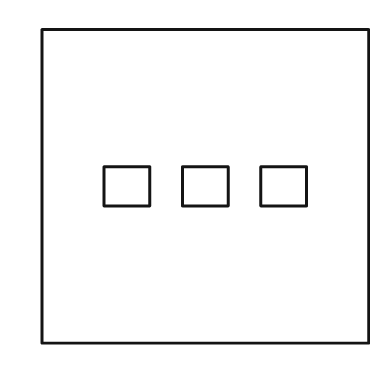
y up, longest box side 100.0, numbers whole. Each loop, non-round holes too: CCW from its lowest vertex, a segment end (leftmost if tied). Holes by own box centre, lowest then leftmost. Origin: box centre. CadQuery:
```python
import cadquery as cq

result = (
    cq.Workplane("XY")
    .moveTo(-50.0, -48.0)
    .lineTo(50.0, -48.0)
    .lineTo(50.0, 48.0)
    .lineTo(-50.0, 48.0)
    .close()
    .moveTo(-31.0, -6.0)
    .lineTo(-17.0, -6.0)
    .lineTo(-17.0, 6.0)
    .lineTo(-31.0, 6.0)
    .close()
    .moveTo(-7.0, -6.0)
    .lineTo(7.0, -6.0)
    .lineTo(7.0, 6.0)
    .lineTo(-7.0, 6.0)
    .close()
    .moveTo(17.0, -6.0)
    .lineTo(31.0, -6.0)
    .lineTo(31.0, 6.0)
    .lineTo(17.0, 6.0)
    .close()
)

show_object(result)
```